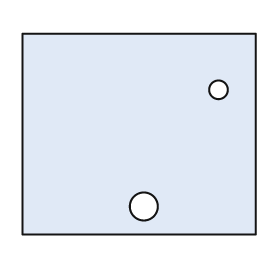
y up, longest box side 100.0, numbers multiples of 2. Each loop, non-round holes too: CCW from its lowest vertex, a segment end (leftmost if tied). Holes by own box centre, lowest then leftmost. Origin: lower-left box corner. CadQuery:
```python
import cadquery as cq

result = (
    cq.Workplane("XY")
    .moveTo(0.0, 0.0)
    .lineTo(100.0, 0.0)
    .lineTo(100.0, 86.0)
    .lineTo(0.0, 86.0)
    .close()
    .moveTo(52.0, 12.0)
    .circle(6.0)
    .moveTo(84.0, 62.0)
    .circle(4.0)
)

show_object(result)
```